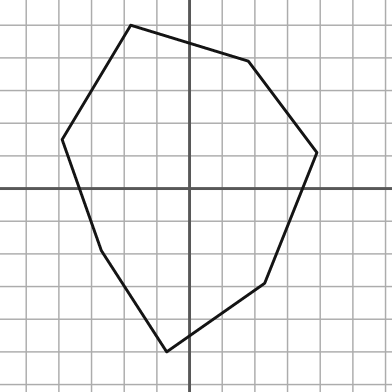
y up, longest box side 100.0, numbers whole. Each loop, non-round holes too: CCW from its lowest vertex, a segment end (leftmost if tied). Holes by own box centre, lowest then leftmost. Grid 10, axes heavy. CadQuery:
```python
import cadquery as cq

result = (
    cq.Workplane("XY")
    .moveTo(-7.0, -50.0)
    .lineTo(23.0, -29.0)
    .lineTo(39.0, 11.0)
    .lineTo(18.0, 39.0)
    .lineTo(-18.0, 50.0)
    .lineTo(-39.0, 15.0)
    .lineTo(-27.0, -19.0)
    .close()
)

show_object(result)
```